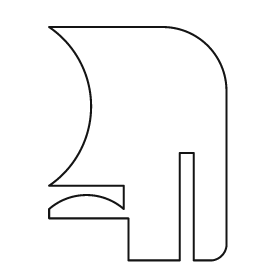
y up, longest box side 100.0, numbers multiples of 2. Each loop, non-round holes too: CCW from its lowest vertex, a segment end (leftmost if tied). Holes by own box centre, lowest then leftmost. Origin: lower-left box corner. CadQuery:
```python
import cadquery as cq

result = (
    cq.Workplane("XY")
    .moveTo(34.0, 0.0)
    .lineTo(56.0, 0.0)
    .lineTo(56.0, 46.0)
    .lineTo(62.0, 46.0)
    .lineTo(62.0, 0.0)
    .lineTo(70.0, 0.0)
    .threePointArc((74.0, 2.0), (76.0, 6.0))
    .lineTo(76.0, 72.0)
    .threePointArc((68.0, 92.0), (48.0, 100.0))
    .lineTo(0.0, 100.0)
    .threePointArc((18.0, 66.0), (0.0, 32.0))
    .lineTo(32.0, 32.0)
    .lineTo(32.0, 22.0)
    .threePointArc((16.0, 28.0), (0.0, 22.0))
    .lineTo(0.0, 18.0)
    .lineTo(34.0, 18.0)
    .close()
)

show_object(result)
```